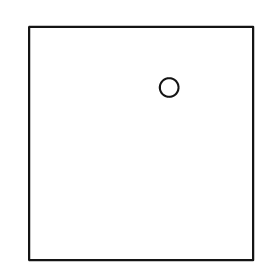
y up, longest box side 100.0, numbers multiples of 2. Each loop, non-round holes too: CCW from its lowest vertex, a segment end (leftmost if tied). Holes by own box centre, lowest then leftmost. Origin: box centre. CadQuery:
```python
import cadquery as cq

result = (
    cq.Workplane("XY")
    .moveTo(-48.0, -50.0)
    .lineTo(48.0, -50.0)
    .lineTo(48.0, 50.0)
    .lineTo(-48.0, 50.0)
    .close()
    .moveTo(12.0, 24.0)
    .circle(4.0)
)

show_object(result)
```